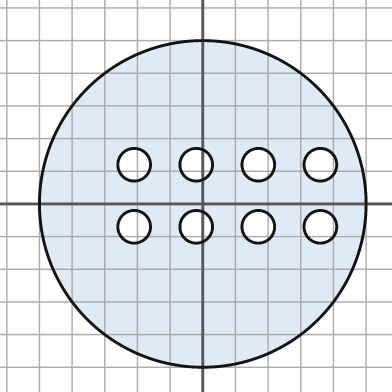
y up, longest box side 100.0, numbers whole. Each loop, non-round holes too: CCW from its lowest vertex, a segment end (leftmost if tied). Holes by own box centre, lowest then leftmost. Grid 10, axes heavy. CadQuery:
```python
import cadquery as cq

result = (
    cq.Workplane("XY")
    .moveTo(0.0, 0.0)
    .circle(50.0)
    .moveTo(-21.0, -7.0)
    .circle(5.0)
    .moveTo(-2.0, -7.0)
    .circle(5.0)
    .moveTo(17.0, -7.0)
    .circle(5.0)
    .moveTo(36.0, -7.0)
    .circle(5.0)
    .moveTo(-21.0, 12.0)
    .circle(5.0)
    .moveTo(-2.0, 12.0)
    .circle(5.0)
    .moveTo(17.0, 12.0)
    .circle(5.0)
    .moveTo(36.0, 12.0)
    .circle(5.0)
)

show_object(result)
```